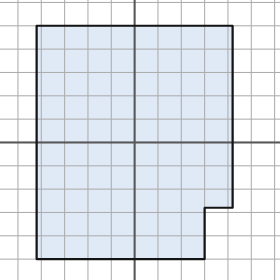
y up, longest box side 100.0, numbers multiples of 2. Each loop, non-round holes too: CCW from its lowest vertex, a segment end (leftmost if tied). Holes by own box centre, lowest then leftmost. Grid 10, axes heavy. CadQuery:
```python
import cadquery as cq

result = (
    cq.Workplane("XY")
    .moveTo(-42.0, -50.0)
    .lineTo(30.0, -50.0)
    .lineTo(30.0, -28.0)
    .lineTo(42.0, -28.0)
    .lineTo(42.0, 50.0)
    .lineTo(-42.0, 50.0)
    .close()
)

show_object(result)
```